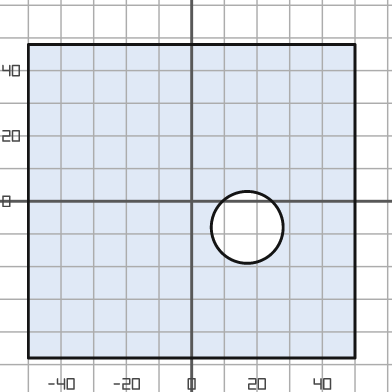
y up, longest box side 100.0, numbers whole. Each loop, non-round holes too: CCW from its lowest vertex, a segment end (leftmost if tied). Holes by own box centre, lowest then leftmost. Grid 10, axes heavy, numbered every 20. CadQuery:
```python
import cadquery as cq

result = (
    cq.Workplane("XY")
    .moveTo(-50.0, -48.0)
    .lineTo(50.0, -48.0)
    .lineTo(50.0, 48.0)
    .lineTo(-50.0, 48.0)
    .close()
    .moveTo(17.0, -8.0)
    .circle(11.0)
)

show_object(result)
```